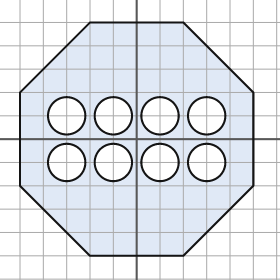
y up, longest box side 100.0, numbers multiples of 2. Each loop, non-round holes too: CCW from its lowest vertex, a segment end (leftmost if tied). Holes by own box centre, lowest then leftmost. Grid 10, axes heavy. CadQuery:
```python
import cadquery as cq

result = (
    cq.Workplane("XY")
    .moveTo(-20.0, -50.0)
    .lineTo(20.0, -50.0)
    .lineTo(50.0, -20.0)
    .lineTo(50.0, 20.0)
    .lineTo(20.0, 50.0)
    .lineTo(-20.0, 50.0)
    .lineTo(-50.0, 20.0)
    .lineTo(-50.0, -20.0)
    .close()
    .moveTo(-30.0, -10.0)
    .circle(8.0)
    .moveTo(-10.0, -10.0)
    .circle(8.0)
    .moveTo(10.0, -10.0)
    .circle(8.0)
    .moveTo(30.0, -10.0)
    .circle(8.0)
    .moveTo(-30.0, 10.0)
    .circle(8.0)
    .moveTo(-10.0, 10.0)
    .circle(8.0)
    .moveTo(10.0, 10.0)
    .circle(8.0)
    .moveTo(30.0, 10.0)
    .circle(8.0)
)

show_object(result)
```